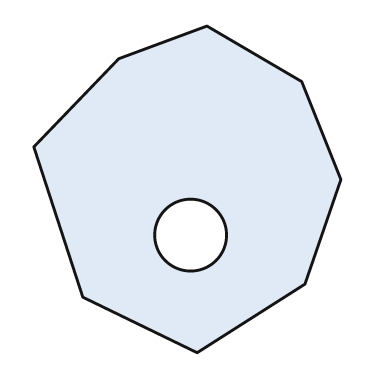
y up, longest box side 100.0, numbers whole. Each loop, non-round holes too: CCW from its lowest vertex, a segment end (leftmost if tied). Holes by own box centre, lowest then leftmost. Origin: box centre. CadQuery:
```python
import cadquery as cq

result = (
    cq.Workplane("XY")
    .moveTo(3.0, -50.0)
    .lineTo(36.0, -29.0)
    .lineTo(47.0, 3.0)
    .lineTo(35.0, 33.0)
    .lineTo(6.0, 50.0)
    .lineTo(-21.0, 40.0)
    .lineTo(-47.0, 13.0)
    .lineTo(-32.0, -33.0)
    .close()
    .moveTo(1.0, -14.0)
    .circle(11.0)
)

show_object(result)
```